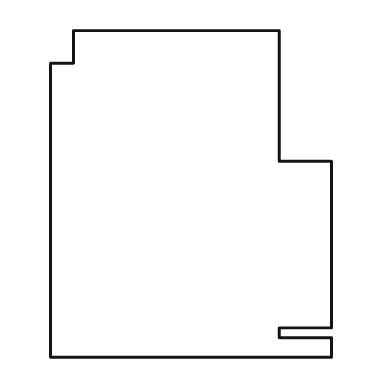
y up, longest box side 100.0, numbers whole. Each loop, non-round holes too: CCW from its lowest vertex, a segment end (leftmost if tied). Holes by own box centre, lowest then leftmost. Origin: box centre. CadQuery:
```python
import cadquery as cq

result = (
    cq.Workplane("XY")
    .moveTo(-43.0, -50.0)
    .lineTo(43.0, -50.0)
    .lineTo(43.0, -44.0)
    .lineTo(27.0, -44.0)
    .lineTo(27.0, -41.0)
    .lineTo(43.0, -41.0)
    .lineTo(43.0, 10.0)
    .lineTo(27.0, 10.0)
    .lineTo(27.0, 50.0)
    .lineTo(-36.0, 50.0)
    .lineTo(-36.0, 40.0)
    .lineTo(-43.0, 40.0)
    .close()
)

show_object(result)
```